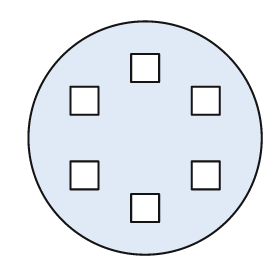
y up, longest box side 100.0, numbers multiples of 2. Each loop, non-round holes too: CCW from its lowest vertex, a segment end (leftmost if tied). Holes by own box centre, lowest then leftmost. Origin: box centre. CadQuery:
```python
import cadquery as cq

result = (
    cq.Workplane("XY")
    .moveTo(0.0, 0.0)
    .circle(50.0)
    .moveTo(-6.0, -36.0)
    .lineTo(6.0, -36.0)
    .lineTo(6.0, -24.0)
    .lineTo(-6.0, -24.0)
    .close()
    .moveTo(-32.0, -22.0)
    .lineTo(-20.0, -22.0)
    .lineTo(-20.0, -10.0)
    .lineTo(-32.0, -10.0)
    .close()
    .moveTo(20.0, -22.0)
    .lineTo(32.0, -22.0)
    .lineTo(32.0, -10.0)
    .lineTo(20.0, -10.0)
    .close()
    .moveTo(-32.0, 10.0)
    .lineTo(-20.0, 10.0)
    .lineTo(-20.0, 22.0)
    .lineTo(-32.0, 22.0)
    .close()
    .moveTo(20.0, 10.0)
    .lineTo(32.0, 10.0)
    .lineTo(32.0, 22.0)
    .lineTo(20.0, 22.0)
    .close()
    .moveTo(-6.0, 24.0)
    .lineTo(6.0, 24.0)
    .lineTo(6.0, 36.0)
    .lineTo(-6.0, 36.0)
    .close()
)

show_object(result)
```